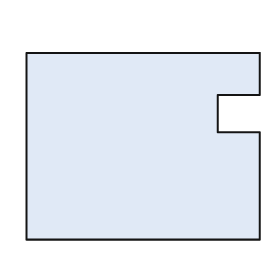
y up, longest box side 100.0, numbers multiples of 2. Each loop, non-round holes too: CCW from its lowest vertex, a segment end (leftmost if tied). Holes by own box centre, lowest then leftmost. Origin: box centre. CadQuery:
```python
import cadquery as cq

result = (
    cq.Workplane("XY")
    .moveTo(-50.0, -40.0)
    .lineTo(50.0, -40.0)
    .lineTo(50.0, 6.0)
    .lineTo(32.0, 6.0)
    .lineTo(32.0, 22.0)
    .lineTo(50.0, 22.0)
    .lineTo(50.0, 40.0)
    .lineTo(-50.0, 40.0)
    .close()
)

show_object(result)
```